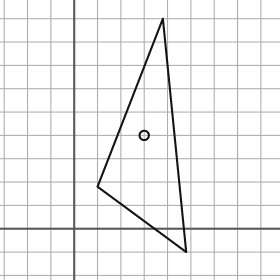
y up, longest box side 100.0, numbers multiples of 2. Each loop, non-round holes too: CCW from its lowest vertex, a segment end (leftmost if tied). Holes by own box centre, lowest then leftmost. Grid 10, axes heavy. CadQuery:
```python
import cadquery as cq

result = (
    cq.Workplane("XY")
    .moveTo(48.0, -10.0)
    .lineTo(38.0, 90.0)
    .lineTo(10.0, 18.0)
    .close()
    .moveTo(30.0, 40.0)
    .circle(2.0)
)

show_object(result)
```